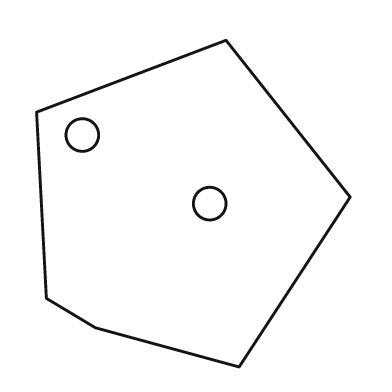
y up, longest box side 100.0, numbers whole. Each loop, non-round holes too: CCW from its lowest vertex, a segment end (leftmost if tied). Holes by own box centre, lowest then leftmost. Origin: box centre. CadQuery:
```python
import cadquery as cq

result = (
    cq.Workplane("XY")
    .moveTo(14.0, -50.0)
    .lineTo(48.0, 2.0)
    .lineTo(10.0, 50.0)
    .lineTo(-48.0, 28.0)
    .lineTo(-45.0, -29.0)
    .lineTo(-30.0, -38.0)
    .close()
    .moveTo(5.0, 0.0)
    .circle(5.0)
    .moveTo(-34.0, 21.0)
    .circle(5.0)
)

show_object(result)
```